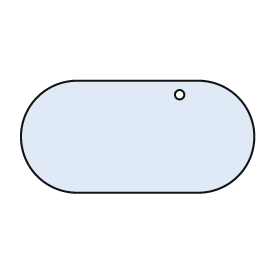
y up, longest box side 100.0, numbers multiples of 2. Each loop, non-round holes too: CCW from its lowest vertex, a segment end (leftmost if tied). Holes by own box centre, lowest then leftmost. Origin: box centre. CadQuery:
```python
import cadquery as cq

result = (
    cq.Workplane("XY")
    .moveTo(-26.0, -24.0)
    .lineTo(26.0, -24.0)
    .threePointArc((50.0, 0.0), (26.0, 24.0))
    .lineTo(-26.0, 24.0)
    .threePointArc((-50.0, 0.0), (-26.0, -24.0))
    .close()
    .moveTo(18.0, 18.0)
    .circle(2.0)
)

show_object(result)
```